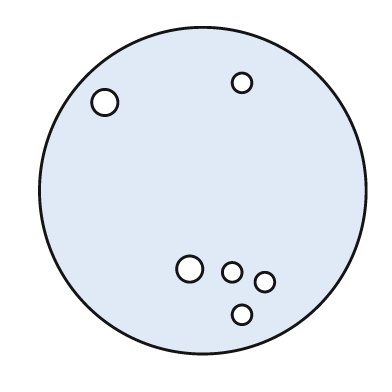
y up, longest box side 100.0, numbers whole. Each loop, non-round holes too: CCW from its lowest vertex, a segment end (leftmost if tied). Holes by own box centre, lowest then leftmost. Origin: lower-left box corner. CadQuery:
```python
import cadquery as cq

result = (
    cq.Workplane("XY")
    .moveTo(50.0, 50.0)
    .circle(50.0)
    .moveTo(62.0, 12.0)
    .circle(3.0)
    .moveTo(69.0, 22.0)
    .circle(3.0)
    .moveTo(59.0, 25.0)
    .circle(3.0)
    .moveTo(46.0, 26.0)
    .circle(4.0)
    .moveTo(20.0, 77.0)
    .circle(4.0)
    .moveTo(62.0, 83.0)
    .circle(3.0)
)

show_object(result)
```